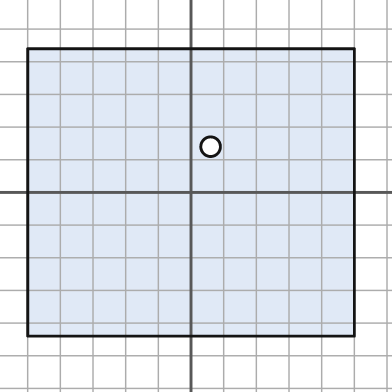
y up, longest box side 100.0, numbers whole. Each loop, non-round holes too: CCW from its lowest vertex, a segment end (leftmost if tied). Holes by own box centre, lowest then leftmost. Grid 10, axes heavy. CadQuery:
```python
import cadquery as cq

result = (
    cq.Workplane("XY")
    .moveTo(-50.0, -44.0)
    .lineTo(50.0, -44.0)
    .lineTo(50.0, 44.0)
    .lineTo(-50.0, 44.0)
    .close()
    .moveTo(6.0, 14.0)
    .circle(3.0)
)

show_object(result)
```